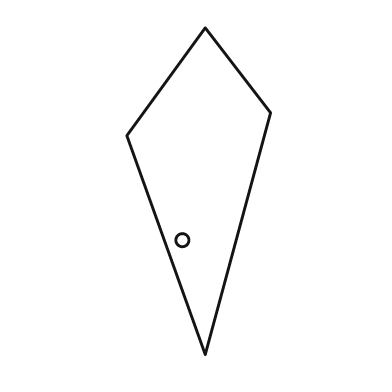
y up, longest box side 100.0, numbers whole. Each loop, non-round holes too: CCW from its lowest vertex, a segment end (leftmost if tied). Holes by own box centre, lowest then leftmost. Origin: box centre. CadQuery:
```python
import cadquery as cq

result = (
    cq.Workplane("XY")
    .moveTo(2.0, -50.0)
    .lineTo(22.0, 24.0)
    .lineTo(2.0, 50.0)
    .lineTo(-22.0, 17.0)
    .close()
    .moveTo(-5.0, -15.0)
    .circle(2.0)
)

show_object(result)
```